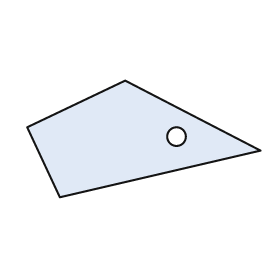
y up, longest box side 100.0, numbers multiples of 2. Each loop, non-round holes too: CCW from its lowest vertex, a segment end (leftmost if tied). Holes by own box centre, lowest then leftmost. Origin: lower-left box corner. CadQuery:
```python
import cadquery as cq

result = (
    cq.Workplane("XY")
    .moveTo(14.0, 0.0)
    .lineTo(100.0, 20.0)
    .lineTo(42.0, 50.0)
    .lineTo(0.0, 30.0)
    .close()
    .moveTo(64.0, 26.0)
    .circle(4.0)
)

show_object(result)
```